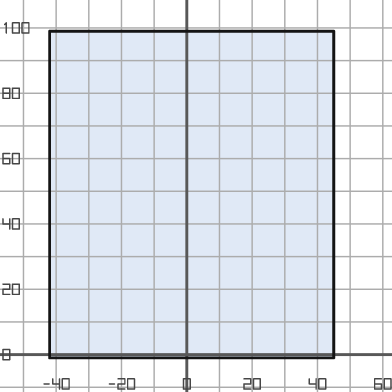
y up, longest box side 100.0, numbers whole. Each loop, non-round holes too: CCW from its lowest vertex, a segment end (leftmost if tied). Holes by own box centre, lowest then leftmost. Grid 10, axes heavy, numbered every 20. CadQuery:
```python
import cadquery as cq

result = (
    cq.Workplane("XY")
    .moveTo(-42.0, -1.0)
    .lineTo(45.0, -1.0)
    .lineTo(45.0, 99.0)
    .lineTo(-42.0, 99.0)
    .close()
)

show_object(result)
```